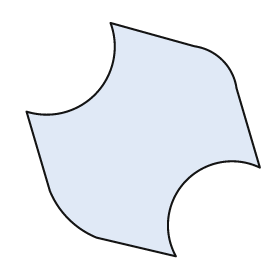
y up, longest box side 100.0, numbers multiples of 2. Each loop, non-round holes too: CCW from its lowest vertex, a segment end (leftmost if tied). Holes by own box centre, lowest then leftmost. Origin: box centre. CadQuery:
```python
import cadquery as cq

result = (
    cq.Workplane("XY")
    .moveTo(14.0, -50.0)
    .threePointArc((18.0, -18.0), (50.0, -12.0))
    .lineTo(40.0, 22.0)
    .threePointArc((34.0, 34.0), (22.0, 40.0))
    .lineTo(-14.0, 50.0)
    .threePointArc((-20.0, 20.0), (-50.0, 12.0))
    .lineTo(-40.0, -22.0)
    .threePointArc((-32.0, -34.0), (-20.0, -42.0))
    .close()
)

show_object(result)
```